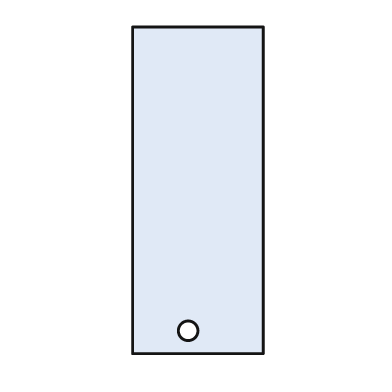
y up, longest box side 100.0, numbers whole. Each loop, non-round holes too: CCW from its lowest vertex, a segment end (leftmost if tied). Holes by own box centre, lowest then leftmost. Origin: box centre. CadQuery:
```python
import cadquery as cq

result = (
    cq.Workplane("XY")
    .moveTo(-20.0, -50.0)
    .lineTo(20.0, -50.0)
    .lineTo(20.0, 50.0)
    .lineTo(-20.0, 50.0)
    .close()
    .moveTo(-3.0, -43.0)
    .circle(3.0)
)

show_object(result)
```